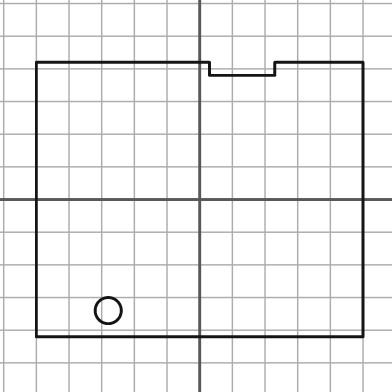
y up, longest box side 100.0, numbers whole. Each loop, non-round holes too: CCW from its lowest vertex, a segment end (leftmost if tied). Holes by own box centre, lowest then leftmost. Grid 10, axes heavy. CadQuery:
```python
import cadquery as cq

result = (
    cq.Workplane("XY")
    .moveTo(-50.0, -42.0)
    .lineTo(50.0, -42.0)
    .lineTo(50.0, 42.0)
    .lineTo(23.0, 42.0)
    .lineTo(23.0, 38.0)
    .lineTo(3.0, 38.0)
    .lineTo(3.0, 42.0)
    .lineTo(-50.0, 42.0)
    .close()
    .moveTo(-28.0, -34.0)
    .circle(4.0)
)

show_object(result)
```